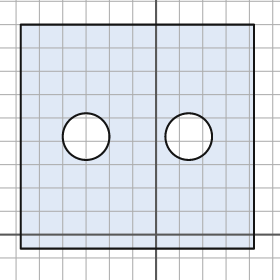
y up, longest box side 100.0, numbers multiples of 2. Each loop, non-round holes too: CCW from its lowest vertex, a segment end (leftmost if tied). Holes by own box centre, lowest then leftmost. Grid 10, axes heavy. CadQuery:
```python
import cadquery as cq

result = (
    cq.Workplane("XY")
    .moveTo(-58.0, -6.0)
    .lineTo(42.0, -6.0)
    .lineTo(42.0, 90.0)
    .lineTo(-58.0, 90.0)
    .close()
    .moveTo(-30.0, 42.0)
    .circle(10.0)
    .moveTo(14.0, 42.0)
    .circle(10.0)
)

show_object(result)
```